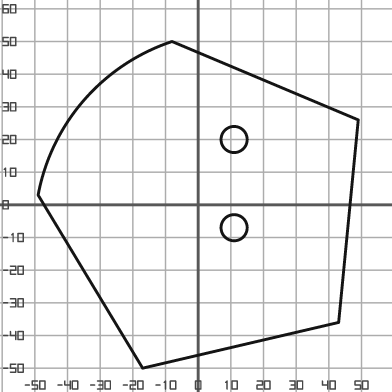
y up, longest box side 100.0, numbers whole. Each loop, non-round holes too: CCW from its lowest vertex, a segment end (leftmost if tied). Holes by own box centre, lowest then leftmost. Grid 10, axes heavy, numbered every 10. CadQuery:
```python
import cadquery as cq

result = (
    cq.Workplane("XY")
    .moveTo(-17.0, -50.0)
    .lineTo(43.0, -36.0)
    .lineTo(49.0, 26.0)
    .lineTo(-8.0, 50.0)
    .threePointArc((-35.0, 32.0), (-49.0, 3.0))
    .close()
    .moveTo(11.0, -7.0)
    .circle(4.0)
    .moveTo(11.0, 20.0)
    .circle(4.0)
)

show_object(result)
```